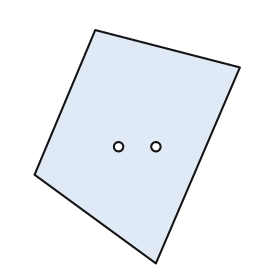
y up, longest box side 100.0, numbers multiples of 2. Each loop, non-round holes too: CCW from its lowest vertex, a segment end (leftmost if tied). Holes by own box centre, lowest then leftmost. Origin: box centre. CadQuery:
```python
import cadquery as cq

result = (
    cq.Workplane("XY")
    .moveTo(8.0, -50.0)
    .lineTo(44.0, 34.0)
    .lineTo(-18.0, 50.0)
    .lineTo(-44.0, -12.0)
    .close()
    .moveTo(-8.0, 0.0)
    .circle(2.0)
    .moveTo(8.0, 0.0)
    .circle(2.0)
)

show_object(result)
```